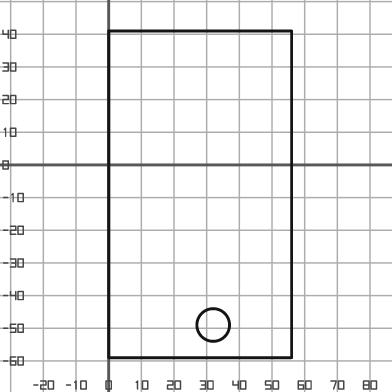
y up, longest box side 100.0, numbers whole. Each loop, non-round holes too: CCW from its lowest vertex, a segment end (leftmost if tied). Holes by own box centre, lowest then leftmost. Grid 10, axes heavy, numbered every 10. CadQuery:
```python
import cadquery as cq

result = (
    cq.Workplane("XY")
    .moveTo(0.0, -59.0)
    .lineTo(56.0, -59.0)
    .lineTo(56.0, 41.0)
    .lineTo(0.0, 41.0)
    .close()
    .moveTo(32.0, -49.0)
    .circle(5.0)
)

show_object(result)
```